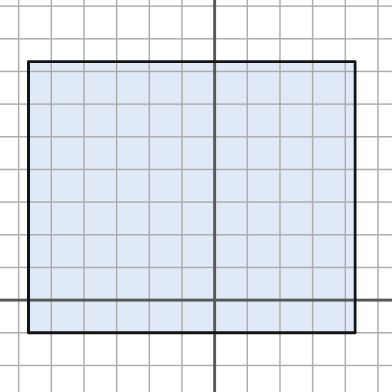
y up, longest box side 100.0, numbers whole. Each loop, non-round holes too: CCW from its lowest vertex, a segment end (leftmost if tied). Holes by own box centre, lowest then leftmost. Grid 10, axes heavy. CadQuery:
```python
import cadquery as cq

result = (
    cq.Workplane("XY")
    .moveTo(-57.0, -10.0)
    .lineTo(43.0, -10.0)
    .lineTo(43.0, 73.0)
    .lineTo(-57.0, 73.0)
    .close()
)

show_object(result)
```